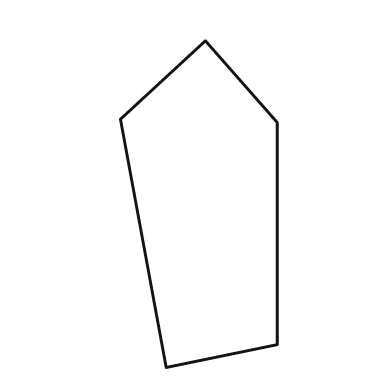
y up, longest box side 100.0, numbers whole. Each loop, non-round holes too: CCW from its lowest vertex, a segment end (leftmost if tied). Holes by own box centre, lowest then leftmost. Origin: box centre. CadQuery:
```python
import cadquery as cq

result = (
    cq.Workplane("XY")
    .moveTo(-10.0, -50.0)
    .lineTo(24.0, -43.0)
    .lineTo(24.0, 25.0)
    .lineTo(2.0, 50.0)
    .lineTo(-24.0, 26.0)
    .close()
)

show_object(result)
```